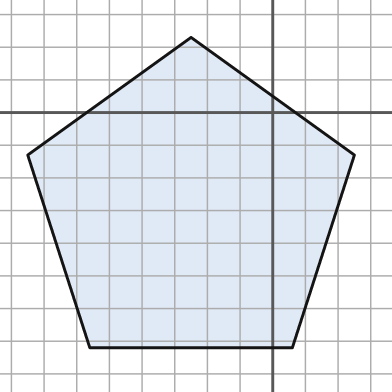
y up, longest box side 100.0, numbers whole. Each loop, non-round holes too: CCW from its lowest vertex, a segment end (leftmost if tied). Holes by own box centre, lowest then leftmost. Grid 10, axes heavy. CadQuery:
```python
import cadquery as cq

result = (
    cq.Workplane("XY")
    .moveTo(-56.0, -72.0)
    .lineTo(6.0, -72.0)
    .lineTo(25.0, -13.0)
    .lineTo(-25.0, 23.0)
    .lineTo(-75.0, -13.0)
    .close()
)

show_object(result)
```